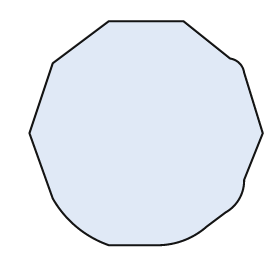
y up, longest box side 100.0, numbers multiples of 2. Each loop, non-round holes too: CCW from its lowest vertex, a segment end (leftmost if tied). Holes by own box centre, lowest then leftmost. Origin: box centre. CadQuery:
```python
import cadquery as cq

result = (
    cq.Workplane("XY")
    .moveTo(-16.0, -48.0)
    .lineTo(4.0, -48.0)
    .threePointArc((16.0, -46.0), (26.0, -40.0))
    .lineTo(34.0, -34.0)
    .threePointArc((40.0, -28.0), (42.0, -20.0))
    .lineTo(50.0, 0.0)
    .lineTo(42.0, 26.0)
    .threePointArc((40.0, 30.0), (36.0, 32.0))
    .lineTo(16.0, 48.0)
    .lineTo(-16.0, 48.0)
    .lineTo(-40.0, 30.0)
    .lineTo(-50.0, 0.0)
    .lineTo(-40.0, -28.0)
    .threePointArc((-30.0, -40.0), (-16.0, -48.0))
    .close()
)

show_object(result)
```